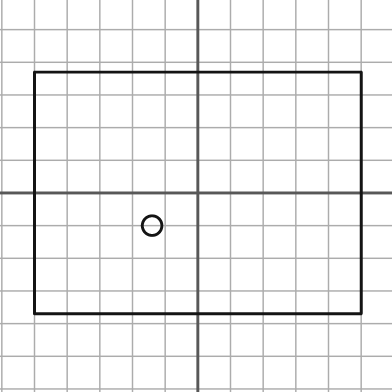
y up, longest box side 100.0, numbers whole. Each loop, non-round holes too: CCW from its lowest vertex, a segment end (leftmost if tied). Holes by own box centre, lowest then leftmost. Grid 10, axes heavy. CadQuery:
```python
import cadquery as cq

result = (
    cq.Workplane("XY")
    .moveTo(-50.0, -37.0)
    .lineTo(50.0, -37.0)
    .lineTo(50.0, 37.0)
    .lineTo(-50.0, 37.0)
    .close()
    .moveTo(-14.0, -10.0)
    .circle(3.0)
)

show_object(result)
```